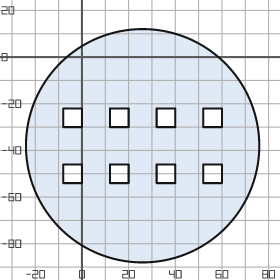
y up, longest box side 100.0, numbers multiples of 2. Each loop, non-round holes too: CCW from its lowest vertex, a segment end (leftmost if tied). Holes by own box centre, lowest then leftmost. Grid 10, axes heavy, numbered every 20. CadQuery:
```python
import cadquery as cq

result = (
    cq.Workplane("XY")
    .moveTo(26.0, -38.0)
    .circle(50.0)
    .moveTo(-8.0, -54.0)
    .lineTo(0.0, -54.0)
    .lineTo(0.0, -46.0)
    .lineTo(-8.0, -46.0)
    .close()
    .moveTo(12.0, -54.0)
    .lineTo(20.0, -54.0)
    .lineTo(20.0, -46.0)
    .lineTo(12.0, -46.0)
    .close()
    .moveTo(32.0, -54.0)
    .lineTo(40.0, -54.0)
    .lineTo(40.0, -46.0)
    .lineTo(32.0, -46.0)
    .close()
    .moveTo(52.0, -54.0)
    .lineTo(60.0, -54.0)
    .lineTo(60.0, -46.0)
    .lineTo(52.0, -46.0)
    .close()
    .moveTo(-8.0, -30.0)
    .lineTo(0.0, -30.0)
    .lineTo(0.0, -22.0)
    .lineTo(-8.0, -22.0)
    .close()
    .moveTo(12.0, -30.0)
    .lineTo(20.0, -30.0)
    .lineTo(20.0, -22.0)
    .lineTo(12.0, -22.0)
    .close()
    .moveTo(32.0, -30.0)
    .lineTo(40.0, -30.0)
    .lineTo(40.0, -22.0)
    .lineTo(32.0, -22.0)
    .close()
    .moveTo(52.0, -30.0)
    .lineTo(60.0, -30.0)
    .lineTo(60.0, -22.0)
    .lineTo(52.0, -22.0)
    .close()
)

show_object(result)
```